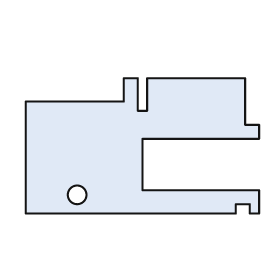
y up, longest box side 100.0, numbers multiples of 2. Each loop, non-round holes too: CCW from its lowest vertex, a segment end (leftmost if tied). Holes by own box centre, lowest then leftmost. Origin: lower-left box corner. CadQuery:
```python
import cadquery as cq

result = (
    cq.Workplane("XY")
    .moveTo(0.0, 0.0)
    .lineTo(90.0, 0.0)
    .lineTo(90.0, 4.0)
    .lineTo(96.0, 4.0)
    .lineTo(96.0, 0.0)
    .lineTo(100.0, 0.0)
    .lineTo(100.0, 10.0)
    .lineTo(50.0, 10.0)
    .lineTo(50.0, 32.0)
    .lineTo(100.0, 32.0)
    .lineTo(100.0, 38.0)
    .lineTo(94.0, 38.0)
    .lineTo(94.0, 58.0)
    .lineTo(52.0, 58.0)
    .lineTo(52.0, 44.0)
    .lineTo(48.0, 44.0)
    .lineTo(48.0, 58.0)
    .lineTo(42.0, 58.0)
    .lineTo(42.0, 48.0)
    .lineTo(0.0, 48.0)
    .close()
    .moveTo(22.0, 8.0)
    .circle(4.0)
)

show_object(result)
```